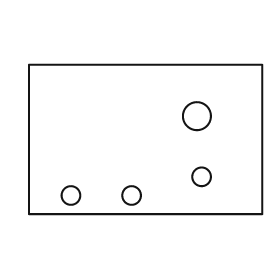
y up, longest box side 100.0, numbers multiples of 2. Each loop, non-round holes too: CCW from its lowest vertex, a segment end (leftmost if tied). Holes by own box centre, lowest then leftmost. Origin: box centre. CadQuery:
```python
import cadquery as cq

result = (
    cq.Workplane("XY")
    .moveTo(-50.0, -32.0)
    .lineTo(50.0, -32.0)
    .lineTo(50.0, 32.0)
    .lineTo(-50.0, 32.0)
    .close()
    .moveTo(-32.0, -24.0)
    .circle(4.0)
    .moveTo(-6.0, -24.0)
    .circle(4.0)
    .moveTo(24.0, -16.0)
    .circle(4.0)
    .moveTo(22.0, 10.0)
    .circle(6.0)
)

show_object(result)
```